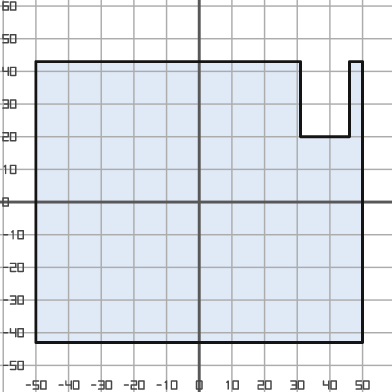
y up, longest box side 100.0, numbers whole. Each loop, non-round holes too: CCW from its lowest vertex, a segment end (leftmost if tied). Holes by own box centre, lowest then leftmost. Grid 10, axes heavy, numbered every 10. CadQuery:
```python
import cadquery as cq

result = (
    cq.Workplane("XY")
    .moveTo(-50.0, -43.0)
    .lineTo(50.0, -43.0)
    .lineTo(50.0, 43.0)
    .lineTo(46.0, 43.0)
    .lineTo(46.0, 20.0)
    .lineTo(31.0, 20.0)
    .lineTo(31.0, 43.0)
    .lineTo(-50.0, 43.0)
    .close()
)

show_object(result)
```